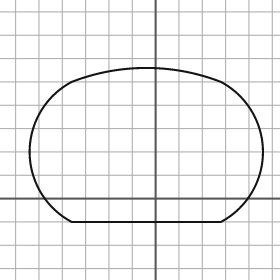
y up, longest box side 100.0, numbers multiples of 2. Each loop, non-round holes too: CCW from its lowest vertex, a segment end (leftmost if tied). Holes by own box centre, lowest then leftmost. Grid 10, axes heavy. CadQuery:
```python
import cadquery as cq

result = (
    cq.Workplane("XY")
    .moveTo(-36.0, -10.0)
    .lineTo(28.0, -10.0)
    .threePointArc((46.0, 20.0), (28.0, 50.0))
    .threePointArc((-4.0, 56.0), (-36.0, 50.0))
    .threePointArc((-54.0, 20.0), (-36.0, -10.0))
    .close()
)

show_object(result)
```